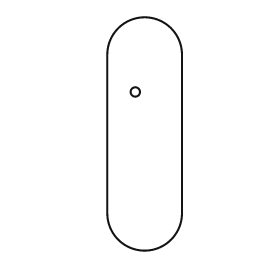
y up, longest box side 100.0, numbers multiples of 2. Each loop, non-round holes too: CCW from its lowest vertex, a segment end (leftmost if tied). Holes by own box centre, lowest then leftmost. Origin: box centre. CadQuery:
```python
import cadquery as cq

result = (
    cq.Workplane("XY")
    .moveTo(-16.0, -34.0)
    .threePointArc((0.0, -50.0), (16.0, -34.0))
    .lineTo(16.0, 34.0)
    .threePointArc((0.0, 50.0), (-16.0, 34.0))
    .close()
    .moveTo(-4.0, 18.0)
    .circle(2.0)
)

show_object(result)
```